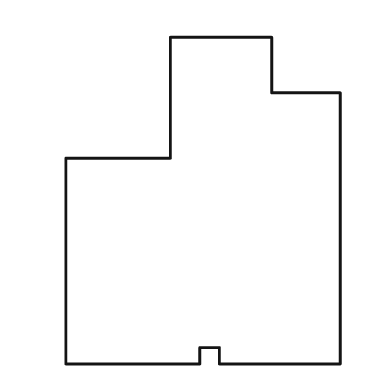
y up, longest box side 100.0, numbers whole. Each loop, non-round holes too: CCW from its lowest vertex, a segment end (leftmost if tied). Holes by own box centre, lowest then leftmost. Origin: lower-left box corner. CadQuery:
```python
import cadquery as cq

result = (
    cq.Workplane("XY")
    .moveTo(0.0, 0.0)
    .lineTo(41.0, 0.0)
    .lineTo(41.0, 5.0)
    .lineTo(47.0, 5.0)
    .lineTo(47.0, 0.0)
    .lineTo(84.0, 0.0)
    .lineTo(84.0, 83.0)
    .lineTo(63.0, 83.0)
    .lineTo(63.0, 100.0)
    .lineTo(32.0, 100.0)
    .lineTo(32.0, 63.0)
    .lineTo(0.0, 63.0)
    .close()
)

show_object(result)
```